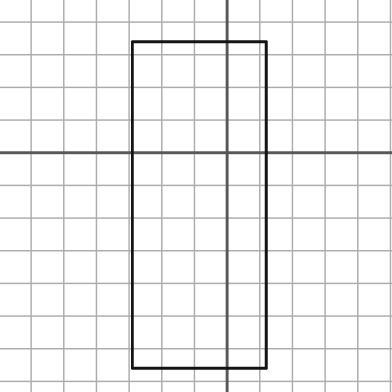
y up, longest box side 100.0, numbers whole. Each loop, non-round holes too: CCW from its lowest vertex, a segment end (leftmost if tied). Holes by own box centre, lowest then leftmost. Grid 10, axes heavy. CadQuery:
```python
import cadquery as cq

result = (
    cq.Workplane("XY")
    .moveTo(-29.0, -66.0)
    .lineTo(12.0, -66.0)
    .lineTo(12.0, 34.0)
    .lineTo(-29.0, 34.0)
    .close()
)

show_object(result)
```